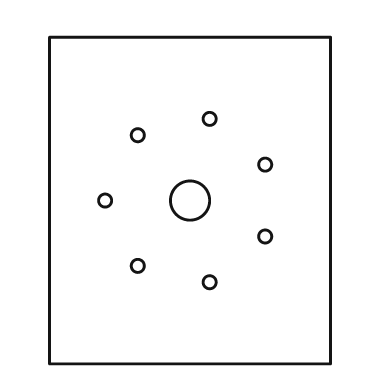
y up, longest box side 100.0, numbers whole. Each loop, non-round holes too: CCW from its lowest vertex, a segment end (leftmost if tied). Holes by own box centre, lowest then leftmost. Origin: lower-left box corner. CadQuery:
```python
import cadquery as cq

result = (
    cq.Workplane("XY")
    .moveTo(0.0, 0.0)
    .lineTo(86.0, 0.0)
    .lineTo(86.0, 100.0)
    .lineTo(0.0, 100.0)
    .close()
    .moveTo(49.0, 25.0)
    .circle(2.0)
    .moveTo(27.0, 30.0)
    .circle(2.0)
    .moveTo(66.0, 39.0)
    .circle(2.0)
    .moveTo(17.0, 50.0)
    .circle(2.0)
    .moveTo(43.0, 50.0)
    .circle(6.0)
    .moveTo(66.0, 61.0)
    .circle(2.0)
    .moveTo(27.0, 70.0)
    .circle(2.0)
    .moveTo(49.0, 75.0)
    .circle(2.0)
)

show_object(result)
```